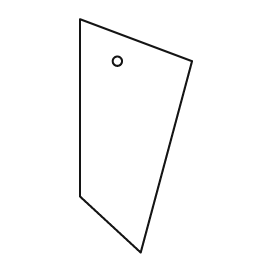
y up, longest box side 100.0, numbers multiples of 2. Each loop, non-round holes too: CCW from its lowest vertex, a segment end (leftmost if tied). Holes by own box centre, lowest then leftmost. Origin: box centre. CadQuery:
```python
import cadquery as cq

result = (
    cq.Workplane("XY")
    .moveTo(2.0, -50.0)
    .lineTo(24.0, 32.0)
    .lineTo(-24.0, 50.0)
    .lineTo(-24.0, -26.0)
    .close()
    .moveTo(-8.0, 32.0)
    .circle(2.0)
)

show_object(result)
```